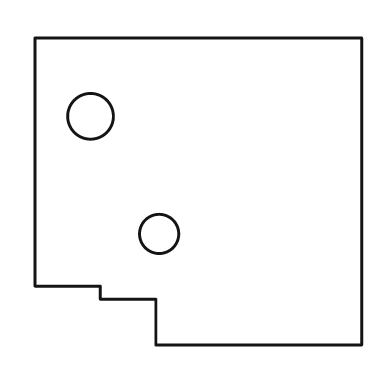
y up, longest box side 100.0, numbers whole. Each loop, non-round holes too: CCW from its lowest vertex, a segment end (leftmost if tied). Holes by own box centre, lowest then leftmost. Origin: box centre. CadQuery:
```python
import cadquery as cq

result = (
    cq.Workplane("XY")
    .moveTo(-13.0, -47.0)
    .lineTo(50.0, -47.0)
    .lineTo(50.0, 47.0)
    .lineTo(-50.0, 47.0)
    .lineTo(-50.0, -29.0)
    .lineTo(-30.0, -29.0)
    .lineTo(-30.0, -33.0)
    .lineTo(-13.0, -33.0)
    .close()
    .moveTo(-12.0, -13.0)
    .circle(6.0)
    .moveTo(-33.0, 23.0)
    .circle(7.0)
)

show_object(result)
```